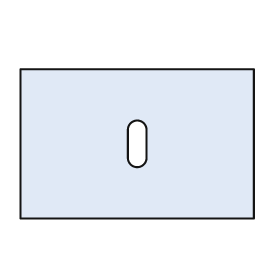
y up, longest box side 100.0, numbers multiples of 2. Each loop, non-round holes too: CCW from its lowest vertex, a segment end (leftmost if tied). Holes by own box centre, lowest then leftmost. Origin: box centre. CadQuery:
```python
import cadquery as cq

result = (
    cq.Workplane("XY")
    .moveTo(-50.0, -32.0)
    .lineTo(50.0, -32.0)
    .lineTo(50.0, 32.0)
    .lineTo(-50.0, 32.0)
    .close()
    .moveTo(-4.0, -6.0)
    .threePointArc((0.0, -10.0), (4.0, -6.0))
    .lineTo(4.0, 6.0)
    .threePointArc((0.0, 10.0), (-4.0, 6.0))
    .close()
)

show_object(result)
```